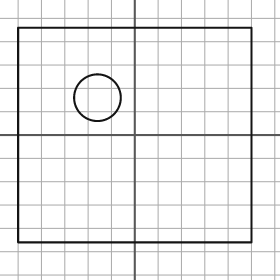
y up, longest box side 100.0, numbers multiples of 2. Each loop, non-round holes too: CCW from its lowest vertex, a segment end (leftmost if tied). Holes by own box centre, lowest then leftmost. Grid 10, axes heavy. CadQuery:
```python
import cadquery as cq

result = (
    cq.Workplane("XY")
    .moveTo(-50.0, -46.0)
    .lineTo(50.0, -46.0)
    .lineTo(50.0, 46.0)
    .lineTo(-50.0, 46.0)
    .close()
    .moveTo(-16.0, 16.0)
    .circle(10.0)
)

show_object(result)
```